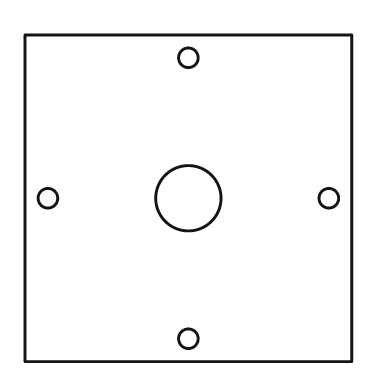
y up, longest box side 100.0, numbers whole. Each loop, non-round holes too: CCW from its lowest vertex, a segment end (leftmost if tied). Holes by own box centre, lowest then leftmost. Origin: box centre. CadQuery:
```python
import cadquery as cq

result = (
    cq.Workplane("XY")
    .moveTo(-50.0, -50.0)
    .lineTo(50.0, -50.0)
    .lineTo(50.0, 50.0)
    .lineTo(-50.0, 50.0)
    .close()
    .moveTo(0.0, -43.0)
    .circle(3.0)
    .moveTo(-43.0, 0.0)
    .circle(3.0)
    .moveTo(0.0, 0.0)
    .circle(10.0)
    .moveTo(43.0, 0.0)
    .circle(3.0)
    .moveTo(0.0, 43.0)
    .circle(3.0)
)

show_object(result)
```